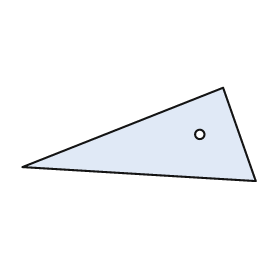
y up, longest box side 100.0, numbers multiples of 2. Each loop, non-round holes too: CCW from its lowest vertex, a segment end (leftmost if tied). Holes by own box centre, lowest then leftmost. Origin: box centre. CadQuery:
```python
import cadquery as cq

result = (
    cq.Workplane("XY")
    .moveTo(50.0, -20.0)
    .lineTo(36.0, 20.0)
    .lineTo(-50.0, -14.0)
    .close()
    .moveTo(26.0, 0.0)
    .circle(2.0)
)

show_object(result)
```